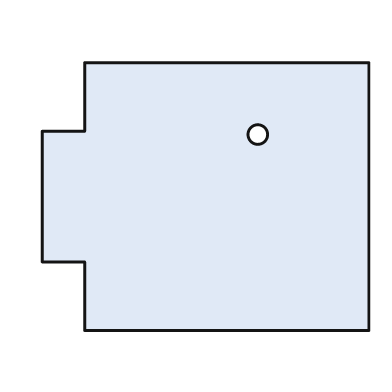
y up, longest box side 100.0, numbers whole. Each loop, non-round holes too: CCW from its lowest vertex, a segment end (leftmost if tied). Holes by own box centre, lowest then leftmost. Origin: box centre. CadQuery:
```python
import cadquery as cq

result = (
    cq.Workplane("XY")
    .moveTo(-37.0, -41.0)
    .lineTo(50.0, -41.0)
    .lineTo(50.0, 41.0)
    .lineTo(-37.0, 41.0)
    .lineTo(-37.0, 20.0)
    .lineTo(-50.0, 20.0)
    .lineTo(-50.0, -20.0)
    .lineTo(-37.0, -20.0)
    .close()
    .moveTo(16.0, 19.0)
    .circle(3.0)
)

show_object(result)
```